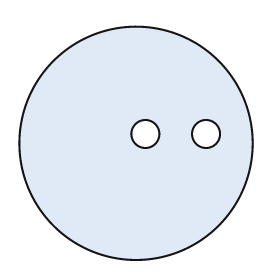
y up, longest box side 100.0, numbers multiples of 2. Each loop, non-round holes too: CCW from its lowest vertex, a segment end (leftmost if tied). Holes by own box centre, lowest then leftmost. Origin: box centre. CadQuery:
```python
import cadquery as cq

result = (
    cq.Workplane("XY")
    .moveTo(0.0, 0.0)
    .circle(50.0)
    .moveTo(4.0, 4.0)
    .circle(6.0)
    .moveTo(30.0, 4.0)
    .circle(6.0)
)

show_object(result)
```